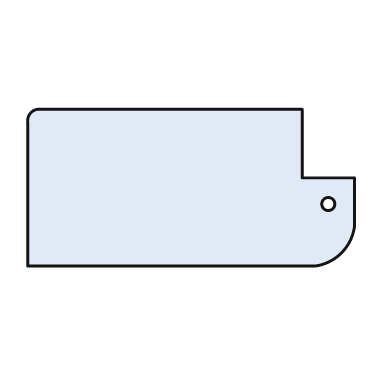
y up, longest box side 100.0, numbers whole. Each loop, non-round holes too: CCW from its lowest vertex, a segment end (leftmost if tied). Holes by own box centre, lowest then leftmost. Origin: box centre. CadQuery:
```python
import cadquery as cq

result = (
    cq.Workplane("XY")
    .moveTo(-50.0, -24.0)
    .lineTo(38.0, -24.0)
    .threePointArc((46.0, -20.0), (50.0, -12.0))
    .lineTo(50.0, 3.0)
    .lineTo(34.0, 3.0)
    .lineTo(34.0, 24.0)
    .lineTo(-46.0, 24.0)
    .threePointArc((-49.0, 23.0), (-50.0, 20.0))
    .close()
    .moveTo(42.0, -5.0)
    .circle(2.0)
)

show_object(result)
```